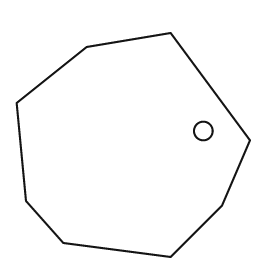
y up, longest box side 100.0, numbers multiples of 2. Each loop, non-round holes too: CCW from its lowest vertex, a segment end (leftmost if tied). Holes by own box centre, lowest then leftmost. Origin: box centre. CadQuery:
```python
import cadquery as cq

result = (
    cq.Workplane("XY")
    .moveTo(16.0, -48.0)
    .lineTo(38.0, -26.0)
    .lineTo(50.0, 2.0)
    .lineTo(16.0, 48.0)
    .lineTo(-20.0, 42.0)
    .lineTo(-50.0, 18.0)
    .lineTo(-46.0, -24.0)
    .lineTo(-30.0, -42.0)
    .close()
    .moveTo(30.0, 6.0)
    .circle(4.0)
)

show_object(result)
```